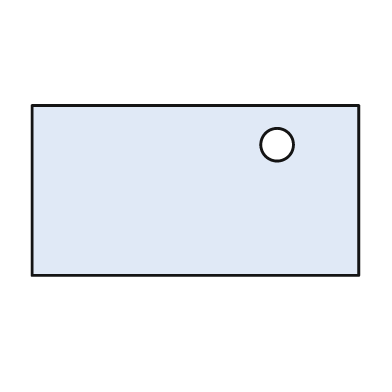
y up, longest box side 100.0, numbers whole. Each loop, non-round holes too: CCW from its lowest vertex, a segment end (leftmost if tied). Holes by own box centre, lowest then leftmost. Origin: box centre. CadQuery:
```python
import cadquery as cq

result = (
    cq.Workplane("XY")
    .moveTo(-50.0, -26.0)
    .lineTo(50.0, -26.0)
    .lineTo(50.0, 26.0)
    .lineTo(-50.0, 26.0)
    .close()
    .moveTo(25.0, 14.0)
    .circle(5.0)
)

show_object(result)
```